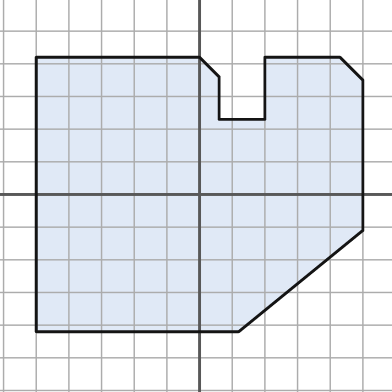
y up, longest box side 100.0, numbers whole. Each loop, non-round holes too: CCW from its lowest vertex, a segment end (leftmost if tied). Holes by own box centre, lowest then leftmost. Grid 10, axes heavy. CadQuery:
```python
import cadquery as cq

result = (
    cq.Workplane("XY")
    .moveTo(-50.0, -42.0)
    .lineTo(12.0, -42.0)
    .lineTo(50.0, -11.0)
    .lineTo(50.0, 35.0)
    .lineTo(43.0, 42.0)
    .lineTo(20.0, 42.0)
    .lineTo(20.0, 23.0)
    .lineTo(6.0, 23.0)
    .lineTo(6.0, 36.0)
    .lineTo(0.0, 42.0)
    .lineTo(-50.0, 42.0)
    .close()
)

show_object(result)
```